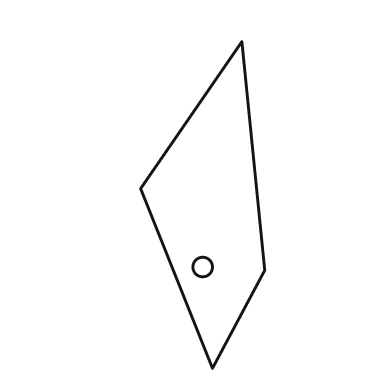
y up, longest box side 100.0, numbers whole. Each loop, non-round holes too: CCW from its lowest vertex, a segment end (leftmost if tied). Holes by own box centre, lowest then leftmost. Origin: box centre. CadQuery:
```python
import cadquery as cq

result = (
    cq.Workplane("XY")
    .moveTo(3.0, -50.0)
    .lineTo(19.0, -20.0)
    .lineTo(12.0, 50.0)
    .lineTo(-19.0, 5.0)
    .close()
    .moveTo(0.0, -19.0)
    .circle(3.0)
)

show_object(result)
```